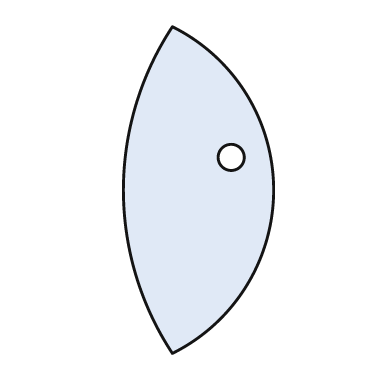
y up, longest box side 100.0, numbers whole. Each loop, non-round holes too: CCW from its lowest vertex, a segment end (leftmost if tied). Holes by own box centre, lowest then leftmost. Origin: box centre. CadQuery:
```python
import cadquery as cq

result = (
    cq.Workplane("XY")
    .moveTo(-8.0, -50.0)
    .threePointArc((23.0, 0.0), (-8.0, 50.0))
    .threePointArc((-23.0, 0.0), (-8.0, -50.0))
    .close()
    .moveTo(10.0, 10.0)
    .circle(4.0)
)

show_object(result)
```